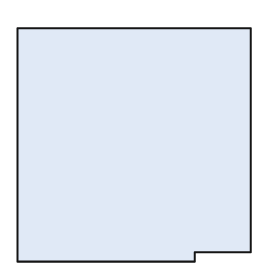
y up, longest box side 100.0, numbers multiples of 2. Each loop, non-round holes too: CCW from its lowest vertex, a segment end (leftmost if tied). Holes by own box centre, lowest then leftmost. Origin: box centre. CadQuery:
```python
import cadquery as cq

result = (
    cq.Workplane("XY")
    .moveTo(-50.0, -50.0)
    .lineTo(26.0, -50.0)
    .lineTo(26.0, -46.0)
    .lineTo(50.0, -46.0)
    .lineTo(50.0, 50.0)
    .lineTo(-50.0, 50.0)
    .close()
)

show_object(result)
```